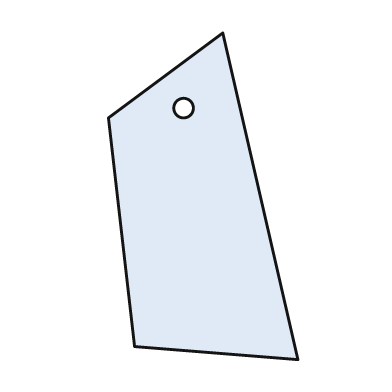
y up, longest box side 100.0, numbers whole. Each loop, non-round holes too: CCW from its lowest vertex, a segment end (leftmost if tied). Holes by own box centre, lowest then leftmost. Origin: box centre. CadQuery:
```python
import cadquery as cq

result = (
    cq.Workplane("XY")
    .moveTo(29.0, -50.0)
    .lineTo(6.0, 50.0)
    .lineTo(-29.0, 24.0)
    .lineTo(-21.0, -46.0)
    .close()
    .moveTo(-6.0, 27.0)
    .circle(3.0)
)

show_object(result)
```